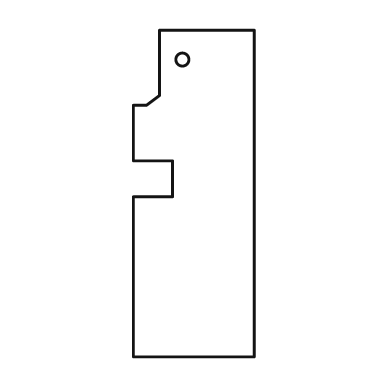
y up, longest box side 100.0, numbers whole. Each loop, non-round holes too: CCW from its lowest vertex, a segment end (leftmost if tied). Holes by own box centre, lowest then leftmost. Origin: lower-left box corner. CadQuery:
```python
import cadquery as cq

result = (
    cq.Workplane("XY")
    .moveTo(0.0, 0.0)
    .lineTo(37.0, 0.0)
    .lineTo(37.0, 100.0)
    .lineTo(8.0, 100.0)
    .lineTo(8.0, 80.0)
    .lineTo(4.0, 77.0)
    .lineTo(0.0, 77.0)
    .lineTo(0.0, 60.0)
    .lineTo(12.0, 60.0)
    .lineTo(12.0, 49.0)
    .lineTo(0.0, 49.0)
    .close()
    .moveTo(15.0, 91.0)
    .circle(2.0)
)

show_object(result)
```